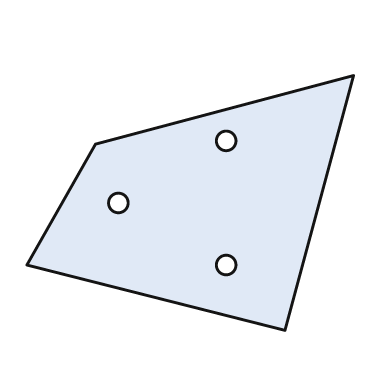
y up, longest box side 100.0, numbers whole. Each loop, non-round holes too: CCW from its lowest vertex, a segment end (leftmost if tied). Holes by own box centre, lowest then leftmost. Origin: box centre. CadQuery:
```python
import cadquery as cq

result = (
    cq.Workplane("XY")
    .moveTo(29.0, -39.0)
    .lineTo(50.0, 39.0)
    .lineTo(-29.0, 18.0)
    .lineTo(-50.0, -19.0)
    .close()
    .moveTo(11.0, -19.0)
    .circle(3.0)
    .moveTo(-22.0, 0.0)
    .circle(3.0)
    .moveTo(11.0, 19.0)
    .circle(3.0)
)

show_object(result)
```